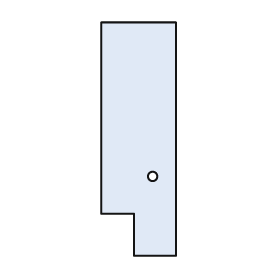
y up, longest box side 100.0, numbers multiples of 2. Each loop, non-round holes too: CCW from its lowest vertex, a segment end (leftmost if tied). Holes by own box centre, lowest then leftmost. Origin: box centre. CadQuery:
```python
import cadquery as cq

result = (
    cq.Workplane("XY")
    .moveTo(-2.0, -50.0)
    .lineTo(16.0, -50.0)
    .lineTo(16.0, 50.0)
    .lineTo(-16.0, 50.0)
    .lineTo(-16.0, -32.0)
    .lineTo(-2.0, -32.0)
    .close()
    .moveTo(6.0, -16.0)
    .circle(2.0)
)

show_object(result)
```